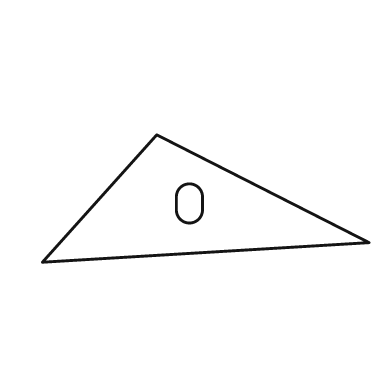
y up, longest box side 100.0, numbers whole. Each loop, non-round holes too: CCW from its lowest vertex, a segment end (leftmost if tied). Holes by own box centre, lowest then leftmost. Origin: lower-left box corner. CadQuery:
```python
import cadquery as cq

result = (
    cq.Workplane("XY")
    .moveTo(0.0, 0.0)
    .lineTo(100.0, 6.0)
    .lineTo(35.0, 39.0)
    .close()
    .moveTo(41.0, 16.0)
    .threePointArc((45.0, 12.0), (49.0, 16.0))
    .lineTo(49.0, 20.0)
    .threePointArc((45.0, 24.0), (41.0, 20.0))
    .close()
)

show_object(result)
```